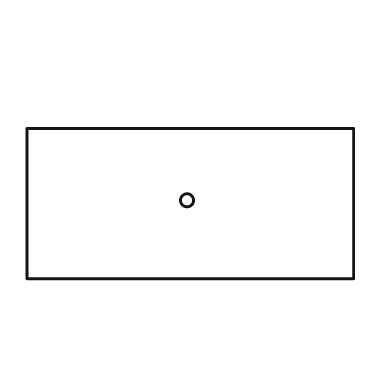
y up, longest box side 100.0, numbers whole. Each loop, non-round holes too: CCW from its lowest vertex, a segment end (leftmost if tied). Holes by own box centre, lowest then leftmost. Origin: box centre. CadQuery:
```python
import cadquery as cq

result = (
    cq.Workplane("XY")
    .moveTo(-50.0, -23.0)
    .lineTo(50.0, -23.0)
    .lineTo(50.0, 23.0)
    .lineTo(-50.0, 23.0)
    .close()
    .moveTo(-1.0, 1.0)
    .circle(2.0)
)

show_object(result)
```